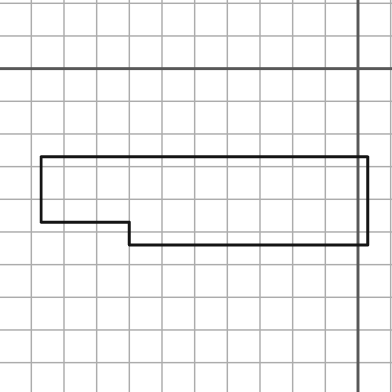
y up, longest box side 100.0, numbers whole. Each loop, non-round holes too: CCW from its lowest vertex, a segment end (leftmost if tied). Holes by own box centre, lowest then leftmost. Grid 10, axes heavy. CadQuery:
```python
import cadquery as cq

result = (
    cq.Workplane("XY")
    .moveTo(-70.0, -54.0)
    .lineTo(3.0, -54.0)
    .lineTo(3.0, -27.0)
    .lineTo(-97.0, -27.0)
    .lineTo(-97.0, -47.0)
    .lineTo(-70.0, -47.0)
    .close()
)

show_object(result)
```